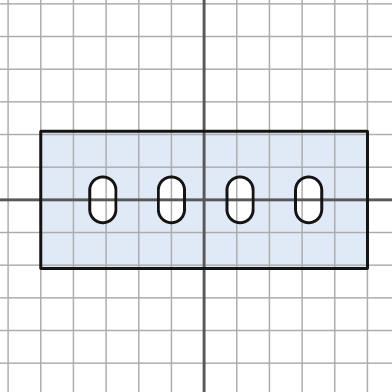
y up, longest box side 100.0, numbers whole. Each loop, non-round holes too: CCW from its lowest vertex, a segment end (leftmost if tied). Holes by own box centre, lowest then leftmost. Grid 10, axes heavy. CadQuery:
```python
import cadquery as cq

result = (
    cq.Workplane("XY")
    .moveTo(-50.0, -21.0)
    .lineTo(50.0, -21.0)
    .lineTo(50.0, 21.0)
    .lineTo(-50.0, 21.0)
    .close()
    .moveTo(-35.0, -3.0)
    .threePointArc((-31.0, -7.0), (-27.0, -3.0))
    .lineTo(-27.0, 3.0)
    .threePointArc((-31.0, 7.0), (-35.0, 3.0))
    .close()
    .moveTo(-14.0, -3.0)
    .threePointArc((-10.0, -7.0), (-6.0, -3.0))
    .lineTo(-6.0, 3.0)
    .threePointArc((-10.0, 7.0), (-14.0, 3.0))
    .close()
    .moveTo(7.0, -3.0)
    .threePointArc((11.0, -7.0), (15.0, -3.0))
    .lineTo(15.0, 3.0)
    .threePointArc((11.0, 7.0), (7.0, 3.0))
    .close()
    .moveTo(28.0, -3.0)
    .threePointArc((32.0, -7.0), (36.0, -3.0))
    .lineTo(36.0, 3.0)
    .threePointArc((32.0, 7.0), (28.0, 3.0))
    .close()
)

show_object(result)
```